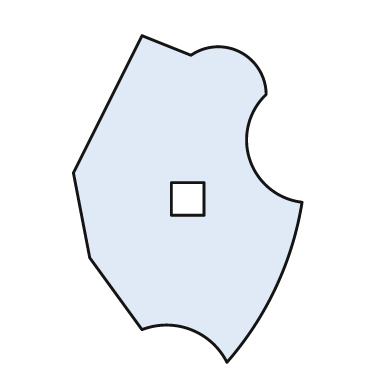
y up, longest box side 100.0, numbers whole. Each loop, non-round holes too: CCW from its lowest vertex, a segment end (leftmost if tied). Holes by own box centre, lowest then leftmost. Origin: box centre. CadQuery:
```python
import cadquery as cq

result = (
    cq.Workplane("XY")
    .moveTo(12.0, -50.0)
    .threePointArc((27.0, -27.0), (35.0, -1.0))
    .threePointArc((19.0, 12.0), (24.0, 32.0))
    .threePointArc((16.0, 45.0), (1.0, 44.0))
    .lineTo(-14.0, 50.0)
    .lineTo(-35.0, 8.0)
    .lineTo(-30.0, -18.0)
    .lineTo(-14.0, -40.0)
    .threePointArc((1.0, -40.0), (12.0, -50.0))
    .close()
    .moveTo(-5.0, -5.0)
    .lineTo(5.0, -5.0)
    .lineTo(5.0, 5.0)
    .lineTo(-5.0, 5.0)
    .close()
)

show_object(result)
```